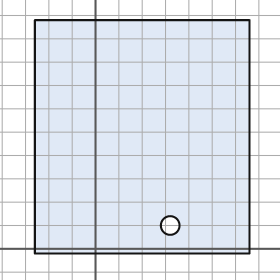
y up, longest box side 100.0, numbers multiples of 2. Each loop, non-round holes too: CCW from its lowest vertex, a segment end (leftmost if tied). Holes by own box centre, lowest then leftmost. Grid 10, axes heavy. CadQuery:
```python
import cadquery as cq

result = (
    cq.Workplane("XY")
    .moveTo(-26.0, -2.0)
    .lineTo(66.0, -2.0)
    .lineTo(66.0, 98.0)
    .lineTo(-26.0, 98.0)
    .close()
    .moveTo(32.0, 10.0)
    .circle(4.0)
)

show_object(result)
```